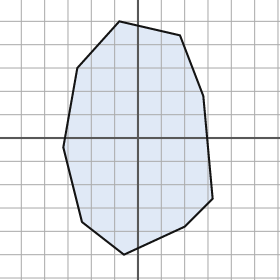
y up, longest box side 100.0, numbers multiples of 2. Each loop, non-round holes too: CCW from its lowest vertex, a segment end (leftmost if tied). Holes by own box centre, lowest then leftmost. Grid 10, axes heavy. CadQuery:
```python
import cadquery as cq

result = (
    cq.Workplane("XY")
    .moveTo(-6.0, -50.0)
    .lineTo(20.0, -38.0)
    .lineTo(32.0, -26.0)
    .lineTo(28.0, 18.0)
    .lineTo(18.0, 44.0)
    .lineTo(-8.0, 50.0)
    .lineTo(-26.0, 30.0)
    .lineTo(-32.0, -4.0)
    .lineTo(-24.0, -36.0)
    .close()
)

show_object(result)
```